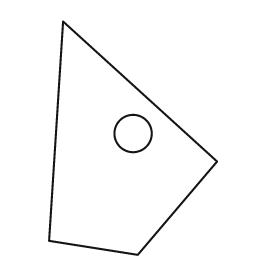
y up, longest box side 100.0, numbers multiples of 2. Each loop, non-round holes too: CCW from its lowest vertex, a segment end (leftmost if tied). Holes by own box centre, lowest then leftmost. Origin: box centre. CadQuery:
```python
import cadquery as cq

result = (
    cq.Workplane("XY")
    .moveTo(2.0, -50.0)
    .lineTo(36.0, -10.0)
    .lineTo(-30.0, 50.0)
    .lineTo(-36.0, -44.0)
    .close()
    .moveTo(0.0, 2.0)
    .circle(8.0)
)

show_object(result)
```